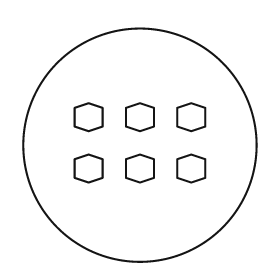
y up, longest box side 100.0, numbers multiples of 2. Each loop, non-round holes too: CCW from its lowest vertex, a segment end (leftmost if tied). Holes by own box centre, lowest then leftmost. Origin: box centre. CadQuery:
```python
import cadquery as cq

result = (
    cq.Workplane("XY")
    .moveTo(0.0, 0.0)
    .circle(50.0)
    .moveTo(-22.0, -16.0)
    .lineTo(-16.0, -14.0)
    .lineTo(-16.0, -6.0)
    .lineTo(-22.0, -4.0)
    .lineTo(-28.0, -6.0)
    .lineTo(-28.0, -14.0)
    .close()
    .moveTo(0.0, -16.0)
    .lineTo(6.0, -14.0)
    .lineTo(6.0, -6.0)
    .lineTo(0.0, -4.0)
    .lineTo(-6.0, -6.0)
    .lineTo(-6.0, -14.0)
    .close()
    .moveTo(22.0, -16.0)
    .lineTo(28.0, -14.0)
    .lineTo(28.0, -6.0)
    .lineTo(22.0, -4.0)
    .lineTo(16.0, -6.0)
    .lineTo(16.0, -14.0)
    .close()
    .moveTo(-22.0, 6.0)
    .lineTo(-16.0, 8.0)
    .lineTo(-16.0, 16.0)
    .lineTo(-22.0, 18.0)
    .lineTo(-28.0, 16.0)
    .lineTo(-28.0, 8.0)
    .close()
    .moveTo(0.0, 6.0)
    .lineTo(6.0, 8.0)
    .lineTo(6.0, 16.0)
    .lineTo(0.0, 18.0)
    .lineTo(-6.0, 16.0)
    .lineTo(-6.0, 8.0)
    .close()
    .moveTo(22.0, 6.0)
    .lineTo(28.0, 8.0)
    .lineTo(28.0, 16.0)
    .lineTo(22.0, 18.0)
    .lineTo(16.0, 16.0)
    .lineTo(16.0, 8.0)
    .close()
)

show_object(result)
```